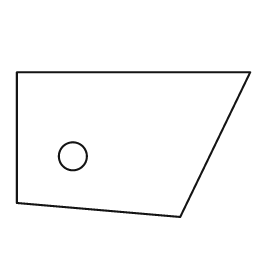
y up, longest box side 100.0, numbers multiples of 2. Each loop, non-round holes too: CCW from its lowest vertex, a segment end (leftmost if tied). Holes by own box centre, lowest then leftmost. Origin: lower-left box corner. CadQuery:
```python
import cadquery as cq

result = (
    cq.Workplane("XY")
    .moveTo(70.0, 0.0)
    .lineTo(100.0, 62.0)
    .lineTo(0.0, 62.0)
    .lineTo(0.0, 6.0)
    .close()
    .moveTo(24.0, 26.0)
    .circle(6.0)
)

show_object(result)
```